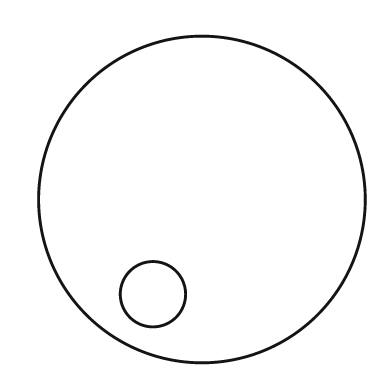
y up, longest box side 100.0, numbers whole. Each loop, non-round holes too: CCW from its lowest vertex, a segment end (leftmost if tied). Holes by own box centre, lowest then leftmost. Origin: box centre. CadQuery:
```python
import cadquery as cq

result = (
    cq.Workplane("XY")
    .moveTo(0.0, 0.0)
    .circle(50.0)
    .moveTo(-15.0, -29.0)
    .circle(10.0)
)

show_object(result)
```